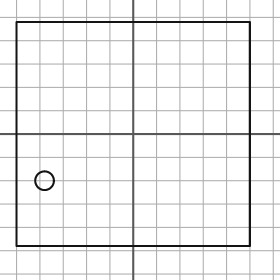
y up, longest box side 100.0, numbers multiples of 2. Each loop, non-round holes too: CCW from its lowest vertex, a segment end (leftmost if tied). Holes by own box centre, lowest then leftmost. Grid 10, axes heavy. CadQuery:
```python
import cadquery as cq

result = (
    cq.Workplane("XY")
    .moveTo(-50.0, -48.0)
    .lineTo(50.0, -48.0)
    .lineTo(50.0, 48.0)
    .lineTo(-50.0, 48.0)
    .close()
    .moveTo(-38.0, -20.0)
    .circle(4.0)
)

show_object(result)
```